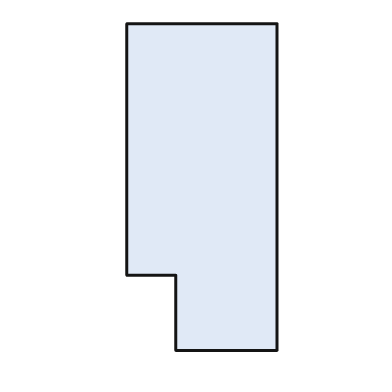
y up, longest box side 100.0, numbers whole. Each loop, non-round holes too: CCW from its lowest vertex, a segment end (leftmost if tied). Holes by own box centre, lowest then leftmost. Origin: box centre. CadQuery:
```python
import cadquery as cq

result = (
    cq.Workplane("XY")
    .moveTo(-8.0, -50.0)
    .lineTo(23.0, -50.0)
    .lineTo(23.0, 50.0)
    .lineTo(-23.0, 50.0)
    .lineTo(-23.0, -27.0)
    .lineTo(-8.0, -27.0)
    .close()
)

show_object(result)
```